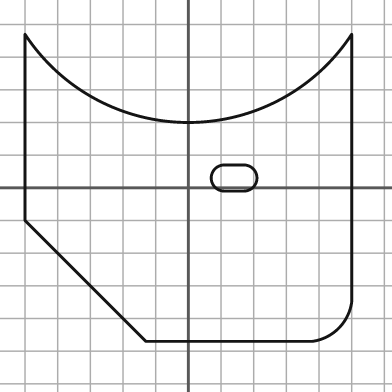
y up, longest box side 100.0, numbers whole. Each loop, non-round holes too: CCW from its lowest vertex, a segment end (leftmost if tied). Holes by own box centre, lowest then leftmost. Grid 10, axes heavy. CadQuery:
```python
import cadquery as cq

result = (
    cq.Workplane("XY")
    .moveTo(-13.0, -47.0)
    .lineTo(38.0, -47.0)
    .threePointArc((46.0, -43.0), (50.0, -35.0))
    .lineTo(50.0, 47.0)
    .threePointArc((0.0, 20.0), (-50.0, 47.0))
    .lineTo(-50.0, -10.0)
    .close()
    .moveTo(11.0, -1.0)
    .lineTo(17.0, -1.0)
    .threePointArc((21.0, 3.0), (17.0, 7.0))
    .lineTo(11.0, 7.0)
    .threePointArc((7.0, 3.0), (11.0, -1.0))
    .close()
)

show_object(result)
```